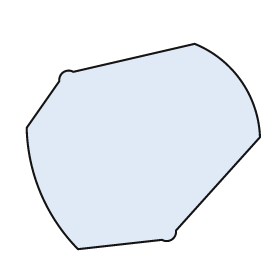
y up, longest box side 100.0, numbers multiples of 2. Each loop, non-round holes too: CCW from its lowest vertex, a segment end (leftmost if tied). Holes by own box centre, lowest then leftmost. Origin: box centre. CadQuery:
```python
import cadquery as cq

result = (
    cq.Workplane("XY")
    .moveTo(-28.0, -44.0)
    .lineTo(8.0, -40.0)
    .threePointArc((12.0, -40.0), (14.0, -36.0))
    .lineTo(50.0, 4.0)
    .threePointArc((42.0, 28.0), (22.0, 44.0))
    .lineTo(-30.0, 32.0)
    .threePointArc((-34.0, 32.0), (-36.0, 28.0))
    .lineTo(-50.0, 8.0)
    .threePointArc((-44.0, -20.0), (-28.0, -44.0))
    .close()
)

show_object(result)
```